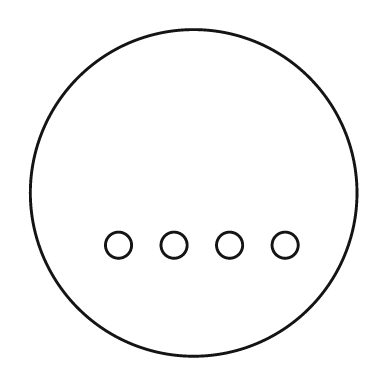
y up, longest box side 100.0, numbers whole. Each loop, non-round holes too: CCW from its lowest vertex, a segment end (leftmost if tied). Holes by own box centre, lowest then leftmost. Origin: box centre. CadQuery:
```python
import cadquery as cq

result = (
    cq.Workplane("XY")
    .moveTo(0.0, 0.0)
    .circle(50.0)
    .moveTo(-23.0, -16.0)
    .circle(4.0)
    .moveTo(-6.0, -16.0)
    .circle(4.0)
    .moveTo(11.0, -16.0)
    .circle(4.0)
    .moveTo(28.0, -16.0)
    .circle(4.0)
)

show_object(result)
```